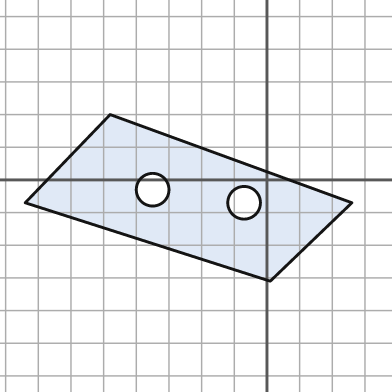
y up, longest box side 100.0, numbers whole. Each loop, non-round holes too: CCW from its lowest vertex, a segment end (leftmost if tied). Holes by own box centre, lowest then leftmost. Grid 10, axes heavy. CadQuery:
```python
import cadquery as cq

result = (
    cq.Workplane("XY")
    .moveTo(1.0, -31.0)
    .lineTo(26.0, -7.0)
    .lineTo(-48.0, 20.0)
    .lineTo(-74.0, -7.0)
    .close()
    .moveTo(-7.0, -7.0)
    .circle(5.0)
    .moveTo(-35.0, -3.0)
    .circle(5.0)
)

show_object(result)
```